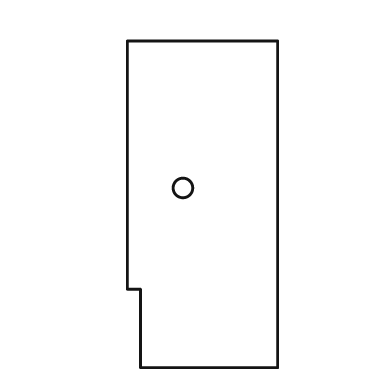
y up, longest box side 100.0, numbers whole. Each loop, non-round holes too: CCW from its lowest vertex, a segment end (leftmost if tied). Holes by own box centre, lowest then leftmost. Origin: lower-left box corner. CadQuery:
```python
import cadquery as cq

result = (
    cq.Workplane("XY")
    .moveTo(4.0, 0.0)
    .lineTo(46.0, 0.0)
    .lineTo(46.0, 100.0)
    .lineTo(0.0, 100.0)
    .lineTo(0.0, 24.0)
    .lineTo(4.0, 24.0)
    .close()
    .moveTo(17.0, 55.0)
    .circle(3.0)
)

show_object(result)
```